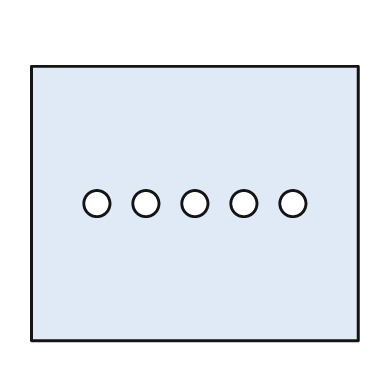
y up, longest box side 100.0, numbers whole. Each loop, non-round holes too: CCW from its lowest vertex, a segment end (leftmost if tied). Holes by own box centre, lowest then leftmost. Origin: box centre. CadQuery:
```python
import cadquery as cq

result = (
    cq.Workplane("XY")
    .moveTo(-50.0, -42.0)
    .lineTo(50.0, -42.0)
    .lineTo(50.0, 42.0)
    .lineTo(-50.0, 42.0)
    .close()
    .moveTo(-30.0, 0.0)
    .circle(4.0)
    .moveTo(-15.0, 0.0)
    .circle(4.0)
    .moveTo(0.0, 0.0)
    .circle(4.0)
    .moveTo(15.0, 0.0)
    .circle(4.0)
    .moveTo(30.0, 0.0)
    .circle(4.0)
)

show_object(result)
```